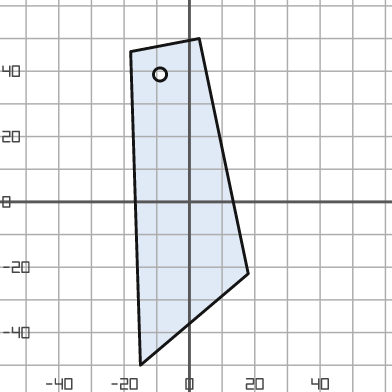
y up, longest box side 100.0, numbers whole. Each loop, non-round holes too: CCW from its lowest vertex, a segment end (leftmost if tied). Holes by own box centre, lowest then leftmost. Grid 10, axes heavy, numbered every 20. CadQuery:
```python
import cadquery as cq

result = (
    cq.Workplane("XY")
    .moveTo(-15.0, -50.0)
    .lineTo(18.0, -22.0)
    .lineTo(3.0, 50.0)
    .lineTo(-18.0, 46.0)
    .close()
    .moveTo(-9.0, 39.0)
    .circle(2.0)
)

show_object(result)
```